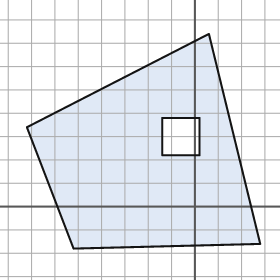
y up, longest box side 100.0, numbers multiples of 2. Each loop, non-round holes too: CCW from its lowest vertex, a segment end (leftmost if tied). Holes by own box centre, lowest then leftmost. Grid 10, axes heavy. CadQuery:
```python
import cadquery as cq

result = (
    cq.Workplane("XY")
    .moveTo(-52.0, -18.0)
    .lineTo(28.0, -16.0)
    .lineTo(6.0, 74.0)
    .lineTo(-72.0, 34.0)
    .close()
    .moveTo(-14.0, 22.0)
    .lineTo(2.0, 22.0)
    .lineTo(2.0, 38.0)
    .lineTo(-14.0, 38.0)
    .close()
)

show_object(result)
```